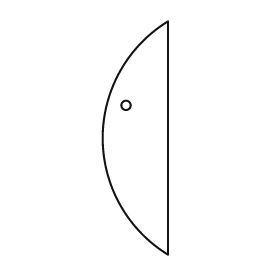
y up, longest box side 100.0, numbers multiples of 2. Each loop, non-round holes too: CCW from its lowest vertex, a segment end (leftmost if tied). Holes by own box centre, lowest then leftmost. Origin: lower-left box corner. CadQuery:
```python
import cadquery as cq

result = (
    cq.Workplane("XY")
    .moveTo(28.0, 0.0)
    .lineTo(28.0, 100.0)
    .threePointArc((0.0, 50.0), (28.0, 0.0))
    .close()
    .moveTo(10.0, 64.0)
    .circle(2.0)
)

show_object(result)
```